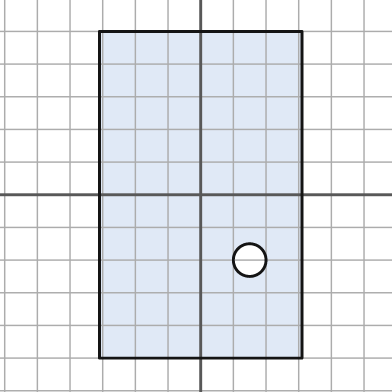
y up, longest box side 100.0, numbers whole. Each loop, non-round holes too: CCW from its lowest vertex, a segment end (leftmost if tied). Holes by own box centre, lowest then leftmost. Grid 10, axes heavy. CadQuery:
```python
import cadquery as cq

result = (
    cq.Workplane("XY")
    .moveTo(-31.0, -50.0)
    .lineTo(31.0, -50.0)
    .lineTo(31.0, 50.0)
    .lineTo(-31.0, 50.0)
    .close()
    .moveTo(15.0, -20.0)
    .circle(5.0)
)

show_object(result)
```